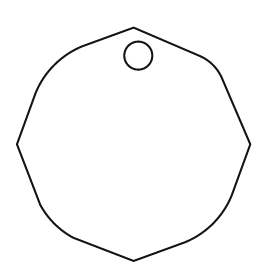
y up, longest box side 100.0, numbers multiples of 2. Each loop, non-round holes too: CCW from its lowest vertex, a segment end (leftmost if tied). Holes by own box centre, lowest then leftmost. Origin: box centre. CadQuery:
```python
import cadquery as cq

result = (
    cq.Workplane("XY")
    .moveTo(0.0, -50.0)
    .lineTo(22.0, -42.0)
    .threePointArc((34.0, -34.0), (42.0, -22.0))
    .lineTo(50.0, 0.0)
    .lineTo(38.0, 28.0)
    .threePointArc((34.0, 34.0), (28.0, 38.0))
    .lineTo(0.0, 50.0)
    .lineTo(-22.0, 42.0)
    .threePointArc((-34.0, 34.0), (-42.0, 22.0))
    .lineTo(-50.0, 0.0)
    .lineTo(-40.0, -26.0)
    .threePointArc((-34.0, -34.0), (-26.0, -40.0))
    .close()
    .moveTo(2.0, 38.0)
    .circle(6.0)
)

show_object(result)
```